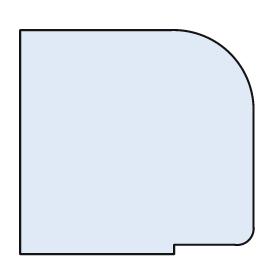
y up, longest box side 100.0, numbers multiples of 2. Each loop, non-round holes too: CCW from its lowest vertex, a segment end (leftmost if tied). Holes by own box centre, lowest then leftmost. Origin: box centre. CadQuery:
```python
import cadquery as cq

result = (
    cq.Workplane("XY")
    .moveTo(-50.0, -48.0)
    .lineTo(16.0, -48.0)
    .lineTo(16.0, -44.0)
    .lineTo(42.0, -44.0)
    .threePointArc((48.0, -42.0), (50.0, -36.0))
    .lineTo(50.0, 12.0)
    .threePointArc((40.0, 38.0), (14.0, 48.0))
    .lineTo(-50.0, 48.0)
    .close()
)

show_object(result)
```